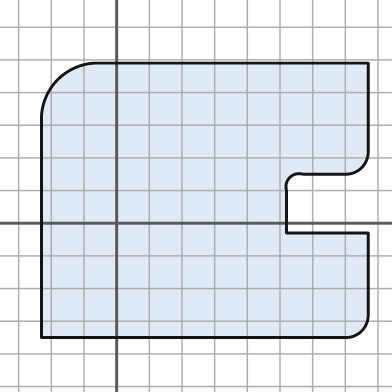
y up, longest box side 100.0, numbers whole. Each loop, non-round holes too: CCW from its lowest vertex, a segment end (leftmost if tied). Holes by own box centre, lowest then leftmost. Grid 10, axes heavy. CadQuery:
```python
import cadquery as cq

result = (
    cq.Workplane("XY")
    .moveTo(-23.0, -35.0)
    .lineTo(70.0, -35.0)
    .threePointArc((75.0, -33.0), (77.0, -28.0))
    .lineTo(77.0, -3.0)
    .lineTo(52.0, -3.0)
    .lineTo(52.0, 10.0)
    .threePointArc((53.0, 14.0), (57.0, 15.0))
    .lineTo(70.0, 15.0)
    .threePointArc((75.0, 17.0), (77.0, 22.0))
    .lineTo(77.0, 49.0)
    .lineTo(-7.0, 49.0)
    .threePointArc((-18.0, 44.0), (-23.0, 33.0))
    .close()
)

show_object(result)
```